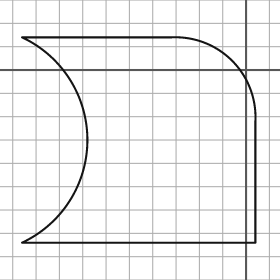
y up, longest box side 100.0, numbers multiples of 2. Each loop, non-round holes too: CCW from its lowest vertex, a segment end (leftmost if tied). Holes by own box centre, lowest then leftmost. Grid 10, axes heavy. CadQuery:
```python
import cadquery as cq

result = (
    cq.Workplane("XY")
    .moveTo(-96.0, -74.0)
    .lineTo(4.0, -74.0)
    .lineTo(4.0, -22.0)
    .threePointArc((-6.0, 4.0), (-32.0, 14.0))
    .lineTo(-96.0, 14.0)
    .threePointArc((-68.0, -30.0), (-96.0, -74.0))
    .close()
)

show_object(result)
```